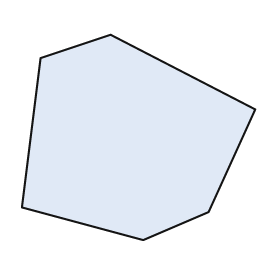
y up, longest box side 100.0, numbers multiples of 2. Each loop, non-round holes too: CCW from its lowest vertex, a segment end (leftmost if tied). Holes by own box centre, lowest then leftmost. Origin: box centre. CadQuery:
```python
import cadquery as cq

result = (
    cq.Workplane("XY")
    .moveTo(2.0, -44.0)
    .lineTo(30.0, -32.0)
    .lineTo(50.0, 12.0)
    .lineTo(-12.0, 44.0)
    .lineTo(-42.0, 34.0)
    .lineTo(-50.0, -30.0)
    .close()
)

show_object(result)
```